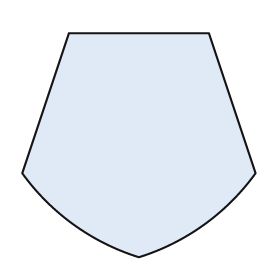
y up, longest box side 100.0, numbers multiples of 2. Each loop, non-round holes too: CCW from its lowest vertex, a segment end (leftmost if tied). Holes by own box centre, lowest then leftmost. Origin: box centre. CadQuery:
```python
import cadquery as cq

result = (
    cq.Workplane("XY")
    .moveTo(0.0, -48.0)
    .threePointArc((28.0, -34.0), (50.0, -12.0))
    .lineTo(30.0, 48.0)
    .lineTo(-30.0, 48.0)
    .lineTo(-50.0, -12.0)
    .threePointArc((-28.0, -34.0), (0.0, -48.0))
    .close()
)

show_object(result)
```